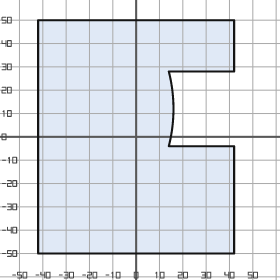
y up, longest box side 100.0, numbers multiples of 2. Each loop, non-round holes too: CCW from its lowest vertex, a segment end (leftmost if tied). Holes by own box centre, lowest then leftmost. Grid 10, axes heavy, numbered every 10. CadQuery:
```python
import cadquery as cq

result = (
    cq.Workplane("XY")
    .moveTo(-42.0, -50.0)
    .lineTo(42.0, -50.0)
    .lineTo(42.0, -4.0)
    .lineTo(14.0, -4.0)
    .threePointArc((16.0, 12.0), (14.0, 28.0))
    .lineTo(42.0, 28.0)
    .lineTo(42.0, 50.0)
    .lineTo(-42.0, 50.0)
    .close()
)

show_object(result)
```